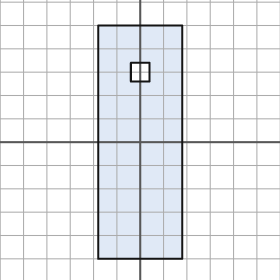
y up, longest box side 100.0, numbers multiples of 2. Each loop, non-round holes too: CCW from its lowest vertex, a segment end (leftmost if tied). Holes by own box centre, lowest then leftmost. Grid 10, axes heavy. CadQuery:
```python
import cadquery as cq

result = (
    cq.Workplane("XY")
    .moveTo(-18.0, -50.0)
    .lineTo(18.0, -50.0)
    .lineTo(18.0, 50.0)
    .lineTo(-18.0, 50.0)
    .close()
    .moveTo(-4.0, 26.0)
    .lineTo(4.0, 26.0)
    .lineTo(4.0, 34.0)
    .lineTo(-4.0, 34.0)
    .close()
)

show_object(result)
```